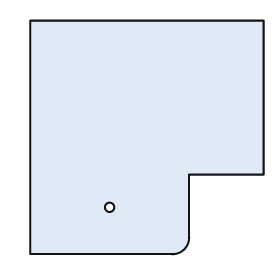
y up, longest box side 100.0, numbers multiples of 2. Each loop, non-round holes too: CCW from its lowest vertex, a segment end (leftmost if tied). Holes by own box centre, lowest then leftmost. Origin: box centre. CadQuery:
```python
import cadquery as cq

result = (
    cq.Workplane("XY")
    .moveTo(-50.0, -50.0)
    .lineTo(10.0, -50.0)
    .threePointArc((16.0, -48.0), (18.0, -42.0))
    .lineTo(18.0, -16.0)
    .lineTo(50.0, -16.0)
    .lineTo(50.0, 50.0)
    .lineTo(-50.0, 50.0)
    .close()
    .moveTo(-16.0, -30.0)
    .circle(2.0)
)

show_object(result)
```